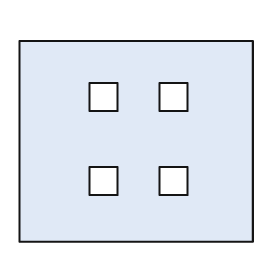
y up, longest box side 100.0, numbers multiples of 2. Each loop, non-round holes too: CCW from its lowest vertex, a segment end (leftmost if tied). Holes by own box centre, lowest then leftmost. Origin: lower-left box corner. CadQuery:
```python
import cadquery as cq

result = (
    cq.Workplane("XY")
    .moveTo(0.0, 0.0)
    .lineTo(100.0, 0.0)
    .lineTo(100.0, 86.0)
    .lineTo(0.0, 86.0)
    .close()
    .moveTo(30.0, 20.0)
    .lineTo(42.0, 20.0)
    .lineTo(42.0, 32.0)
    .lineTo(30.0, 32.0)
    .close()
    .moveTo(60.0, 20.0)
    .lineTo(72.0, 20.0)
    .lineTo(72.0, 32.0)
    .lineTo(60.0, 32.0)
    .close()
    .moveTo(30.0, 56.0)
    .lineTo(42.0, 56.0)
    .lineTo(42.0, 68.0)
    .lineTo(30.0, 68.0)
    .close()
    .moveTo(60.0, 56.0)
    .lineTo(72.0, 56.0)
    .lineTo(72.0, 68.0)
    .lineTo(60.0, 68.0)
    .close()
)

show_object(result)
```